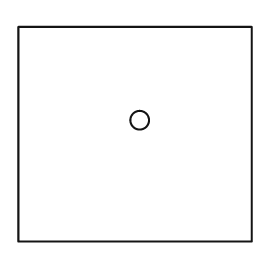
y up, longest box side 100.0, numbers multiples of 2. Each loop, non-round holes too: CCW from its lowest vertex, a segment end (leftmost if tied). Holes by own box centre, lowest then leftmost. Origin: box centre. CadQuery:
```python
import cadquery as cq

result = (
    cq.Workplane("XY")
    .moveTo(-50.0, -46.0)
    .lineTo(50.0, -46.0)
    .lineTo(50.0, 46.0)
    .lineTo(-50.0, 46.0)
    .close()
    .moveTo(2.0, 6.0)
    .circle(4.0)
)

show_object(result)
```